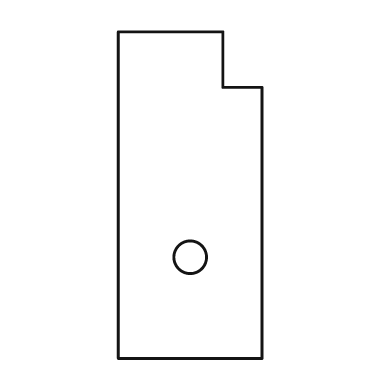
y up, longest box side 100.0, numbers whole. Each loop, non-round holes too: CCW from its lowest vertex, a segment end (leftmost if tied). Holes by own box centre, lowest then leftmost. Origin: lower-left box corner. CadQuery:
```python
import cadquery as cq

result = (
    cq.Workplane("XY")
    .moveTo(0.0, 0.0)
    .lineTo(44.0, 0.0)
    .lineTo(44.0, 83.0)
    .lineTo(32.0, 83.0)
    .lineTo(32.0, 100.0)
    .lineTo(0.0, 100.0)
    .close()
    .moveTo(22.0, 31.0)
    .circle(5.0)
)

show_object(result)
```